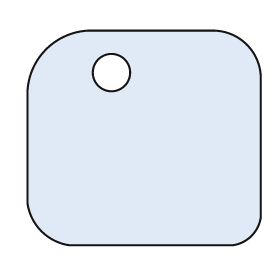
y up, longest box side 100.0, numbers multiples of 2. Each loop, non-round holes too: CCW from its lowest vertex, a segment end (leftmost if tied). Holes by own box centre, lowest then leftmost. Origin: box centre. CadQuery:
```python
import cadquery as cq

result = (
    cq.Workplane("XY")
    .moveTo(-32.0, -46.0)
    .lineTo(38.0, -46.0)
    .threePointArc((46.0, -42.0), (50.0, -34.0))
    .lineTo(50.0, 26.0)
    .threePointArc((44.0, 40.0), (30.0, 46.0))
    .lineTo(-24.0, 46.0)
    .threePointArc((-42.0, 38.0), (-50.0, 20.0))
    .lineTo(-50.0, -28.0)
    .threePointArc((-44.0, -40.0), (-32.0, -46.0))
    .close()
    .moveTo(-14.0, 28.0)
    .circle(8.0)
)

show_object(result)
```